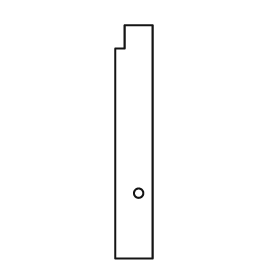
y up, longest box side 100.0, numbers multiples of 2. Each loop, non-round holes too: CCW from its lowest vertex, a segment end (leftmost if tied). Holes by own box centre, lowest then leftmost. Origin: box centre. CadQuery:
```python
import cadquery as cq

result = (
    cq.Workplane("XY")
    .moveTo(-8.0, -50.0)
    .lineTo(8.0, -50.0)
    .lineTo(8.0, 50.0)
    .lineTo(-4.0, 50.0)
    .lineTo(-4.0, 40.0)
    .lineTo(-8.0, 40.0)
    .close()
    .moveTo(2.0, -22.0)
    .circle(2.0)
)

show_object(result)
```